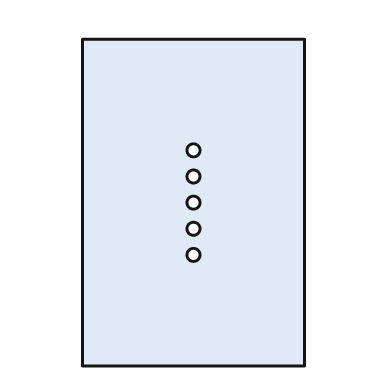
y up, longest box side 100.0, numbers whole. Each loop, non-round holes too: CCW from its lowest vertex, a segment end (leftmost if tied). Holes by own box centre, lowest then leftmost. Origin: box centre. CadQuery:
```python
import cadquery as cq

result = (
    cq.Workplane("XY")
    .moveTo(-34.0, -50.0)
    .lineTo(34.0, -50.0)
    .lineTo(34.0, 50.0)
    .lineTo(-34.0, 50.0)
    .close()
    .moveTo(0.0, -16.0)
    .circle(2.0)
    .moveTo(0.0, -8.0)
    .circle(2.0)
    .moveTo(0.0, 0.0)
    .circle(2.0)
    .moveTo(0.0, 8.0)
    .circle(2.0)
    .moveTo(0.0, 16.0)
    .circle(2.0)
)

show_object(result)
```